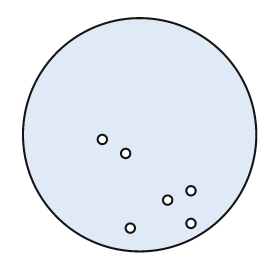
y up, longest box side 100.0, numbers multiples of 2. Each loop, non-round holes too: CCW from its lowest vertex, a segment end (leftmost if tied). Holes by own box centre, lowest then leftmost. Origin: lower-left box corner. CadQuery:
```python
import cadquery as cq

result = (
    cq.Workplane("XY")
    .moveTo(50.0, 50.0)
    .circle(50.0)
    .moveTo(46.0, 10.0)
    .circle(2.0)
    .moveTo(72.0, 12.0)
    .circle(2.0)
    .moveTo(62.0, 22.0)
    .circle(2.0)
    .moveTo(72.0, 26.0)
    .circle(2.0)
    .moveTo(44.0, 42.0)
    .circle(2.0)
    .moveTo(34.0, 48.0)
    .circle(2.0)
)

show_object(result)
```